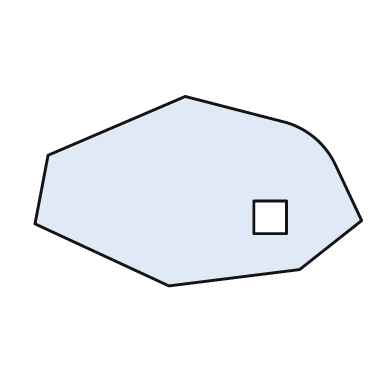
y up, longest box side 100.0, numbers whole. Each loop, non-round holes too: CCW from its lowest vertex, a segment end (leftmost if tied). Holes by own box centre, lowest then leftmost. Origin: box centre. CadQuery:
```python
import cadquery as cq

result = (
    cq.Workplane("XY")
    .moveTo(-9.0, -29.0)
    .lineTo(31.0, -24.0)
    .lineTo(50.0, -9.0)
    .lineTo(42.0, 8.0)
    .threePointArc((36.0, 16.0), (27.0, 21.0))
    .lineTo(-4.0, 29.0)
    .lineTo(-46.0, 11.0)
    .lineTo(-50.0, -10.0)
    .close()
    .moveTo(17.0, -13.0)
    .lineTo(27.0, -13.0)
    .lineTo(27.0, -3.0)
    .lineTo(17.0, -3.0)
    .close()
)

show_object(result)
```